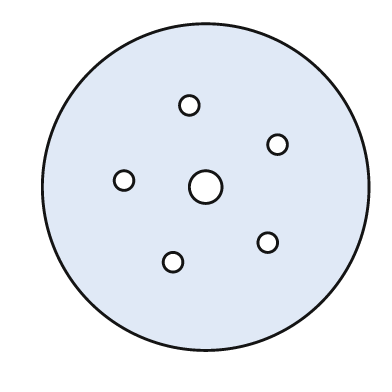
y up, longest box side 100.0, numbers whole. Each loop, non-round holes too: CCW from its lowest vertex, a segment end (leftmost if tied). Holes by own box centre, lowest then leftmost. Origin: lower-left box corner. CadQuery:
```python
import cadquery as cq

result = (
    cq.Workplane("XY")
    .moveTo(50.0, 50.0)
    .circle(50.0)
    .moveTo(40.0, 27.0)
    .circle(3.0)
    .moveTo(69.0, 33.0)
    .circle(3.0)
    .moveTo(50.0, 50.0)
    .circle(5.0)
    .moveTo(25.0, 52.0)
    .circle(3.0)
    .moveTo(72.0, 63.0)
    .circle(3.0)
    .moveTo(45.0, 75.0)
    .circle(3.0)
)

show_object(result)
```